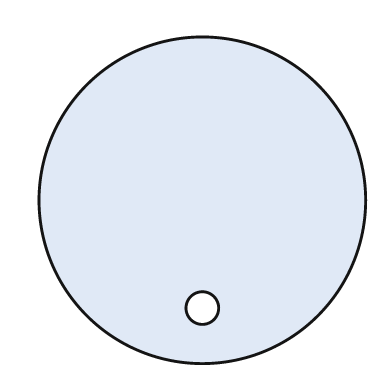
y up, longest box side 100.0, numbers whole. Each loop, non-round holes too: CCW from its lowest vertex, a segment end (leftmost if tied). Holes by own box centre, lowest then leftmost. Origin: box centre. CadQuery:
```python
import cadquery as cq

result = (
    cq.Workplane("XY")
    .moveTo(0.0, 0.0)
    .circle(50.0)
    .moveTo(0.0, -33.0)
    .circle(5.0)
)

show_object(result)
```